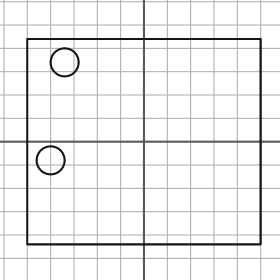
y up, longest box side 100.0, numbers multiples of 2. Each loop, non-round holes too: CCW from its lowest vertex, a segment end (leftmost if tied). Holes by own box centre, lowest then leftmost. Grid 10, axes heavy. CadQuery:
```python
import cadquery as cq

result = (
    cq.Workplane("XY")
    .moveTo(-50.0, -44.0)
    .lineTo(50.0, -44.0)
    .lineTo(50.0, 44.0)
    .lineTo(-50.0, 44.0)
    .close()
    .moveTo(-40.0, -8.0)
    .circle(6.0)
    .moveTo(-34.0, 34.0)
    .circle(6.0)
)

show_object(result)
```